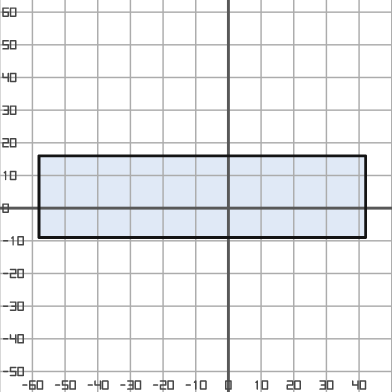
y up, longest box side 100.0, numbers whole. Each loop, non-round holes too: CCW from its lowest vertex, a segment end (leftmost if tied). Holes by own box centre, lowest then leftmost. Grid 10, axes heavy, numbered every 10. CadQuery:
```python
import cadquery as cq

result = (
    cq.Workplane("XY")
    .moveTo(-58.0, -9.0)
    .lineTo(42.0, -9.0)
    .lineTo(42.0, 16.0)
    .lineTo(-58.0, 16.0)
    .close()
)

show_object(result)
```